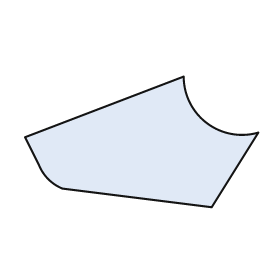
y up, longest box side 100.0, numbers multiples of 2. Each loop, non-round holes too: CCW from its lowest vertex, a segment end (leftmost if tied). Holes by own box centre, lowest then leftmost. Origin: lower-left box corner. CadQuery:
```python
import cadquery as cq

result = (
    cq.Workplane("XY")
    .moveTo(80.0, 0.0)
    .lineTo(100.0, 32.0)
    .threePointArc((78.0, 36.0), (68.0, 56.0))
    .lineTo(0.0, 30.0)
    .lineTo(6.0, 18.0)
    .threePointArc((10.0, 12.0), (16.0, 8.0))
    .close()
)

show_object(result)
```